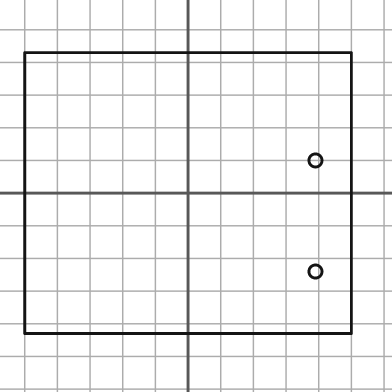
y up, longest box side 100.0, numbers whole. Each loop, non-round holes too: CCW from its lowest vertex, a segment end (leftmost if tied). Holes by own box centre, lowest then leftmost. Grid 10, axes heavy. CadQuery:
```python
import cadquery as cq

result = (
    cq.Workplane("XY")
    .moveTo(-50.0, -43.0)
    .lineTo(50.0, -43.0)
    .lineTo(50.0, 43.0)
    .lineTo(-50.0, 43.0)
    .close()
    .moveTo(39.0, -24.0)
    .circle(2.0)
    .moveTo(39.0, 10.0)
    .circle(2.0)
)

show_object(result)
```